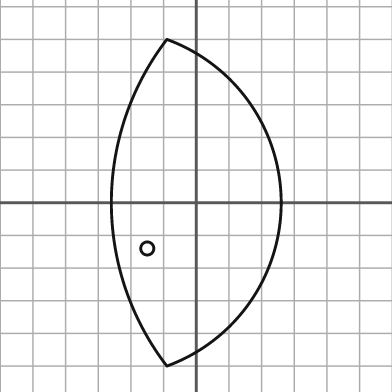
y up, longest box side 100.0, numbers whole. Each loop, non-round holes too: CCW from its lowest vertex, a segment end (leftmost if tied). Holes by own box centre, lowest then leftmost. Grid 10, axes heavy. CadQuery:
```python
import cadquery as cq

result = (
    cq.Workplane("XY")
    .moveTo(-9.0, -50.0)
    .threePointArc((26.0, 0.0), (-9.0, 50.0))
    .threePointArc((-26.0, 0.0), (-9.0, -50.0))
    .close()
    .moveTo(-15.0, -14.0)
    .circle(2.0)
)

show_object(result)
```